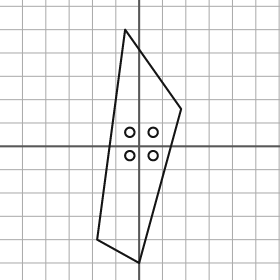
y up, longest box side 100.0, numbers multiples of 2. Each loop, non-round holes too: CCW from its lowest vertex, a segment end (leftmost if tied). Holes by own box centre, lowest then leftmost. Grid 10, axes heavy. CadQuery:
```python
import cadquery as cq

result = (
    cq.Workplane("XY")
    .moveTo(0.0, -50.0)
    .lineTo(18.0, 16.0)
    .lineTo(-6.0, 50.0)
    .lineTo(-18.0, -40.0)
    .close()
    .moveTo(-4.0, -4.0)
    .circle(2.0)
    .moveTo(6.0, -4.0)
    .circle(2.0)
    .moveTo(-4.0, 6.0)
    .circle(2.0)
    .moveTo(6.0, 6.0)
    .circle(2.0)
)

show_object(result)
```